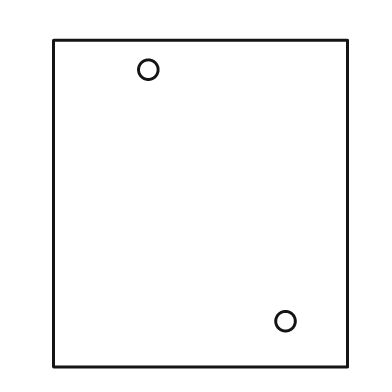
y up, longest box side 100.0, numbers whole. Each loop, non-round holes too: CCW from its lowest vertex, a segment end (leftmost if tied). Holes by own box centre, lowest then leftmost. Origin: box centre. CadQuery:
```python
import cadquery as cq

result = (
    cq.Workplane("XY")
    .moveTo(-45.0, -50.0)
    .lineTo(45.0, -50.0)
    .lineTo(45.0, 50.0)
    .lineTo(-45.0, 50.0)
    .close()
    .moveTo(26.0, -36.0)
    .circle(3.0)
    .moveTo(-16.0, 41.0)
    .circle(3.0)
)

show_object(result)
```